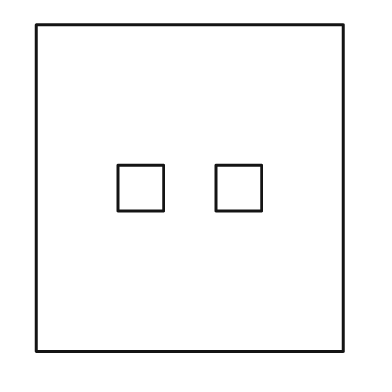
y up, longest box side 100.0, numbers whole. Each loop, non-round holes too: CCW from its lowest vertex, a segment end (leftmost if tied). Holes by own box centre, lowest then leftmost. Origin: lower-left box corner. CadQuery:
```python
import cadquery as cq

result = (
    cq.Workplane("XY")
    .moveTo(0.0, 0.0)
    .lineTo(94.0, 0.0)
    .lineTo(94.0, 100.0)
    .lineTo(0.0, 100.0)
    .close()
    .moveTo(25.0, 43.0)
    .lineTo(39.0, 43.0)
    .lineTo(39.0, 57.0)
    .lineTo(25.0, 57.0)
    .close()
    .moveTo(55.0, 43.0)
    .lineTo(69.0, 43.0)
    .lineTo(69.0, 57.0)
    .lineTo(55.0, 57.0)
    .close()
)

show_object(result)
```